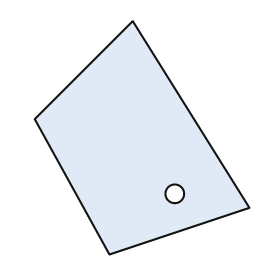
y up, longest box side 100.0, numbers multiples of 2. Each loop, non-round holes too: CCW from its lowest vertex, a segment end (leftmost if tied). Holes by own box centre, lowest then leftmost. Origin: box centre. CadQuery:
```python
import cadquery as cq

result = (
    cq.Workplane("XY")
    .moveTo(-14.0, -50.0)
    .lineTo(46.0, -30.0)
    .lineTo(-4.0, 50.0)
    .lineTo(-46.0, 8.0)
    .close()
    .moveTo(14.0, -24.0)
    .circle(4.0)
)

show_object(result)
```